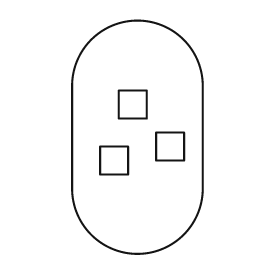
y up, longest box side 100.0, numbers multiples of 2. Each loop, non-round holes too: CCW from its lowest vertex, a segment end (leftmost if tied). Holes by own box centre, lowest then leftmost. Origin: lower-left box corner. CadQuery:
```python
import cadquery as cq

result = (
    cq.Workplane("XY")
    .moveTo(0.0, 28.0)
    .threePointArc((28.0, 0.0), (56.0, 28.0))
    .lineTo(56.0, 72.0)
    .threePointArc((28.0, 100.0), (0.0, 72.0))
    .close()
    .moveTo(12.0, 34.0)
    .lineTo(24.0, 34.0)
    .lineTo(24.0, 46.0)
    .lineTo(12.0, 46.0)
    .close()
    .moveTo(36.0, 40.0)
    .lineTo(48.0, 40.0)
    .lineTo(48.0, 52.0)
    .lineTo(36.0, 52.0)
    .close()
    .moveTo(20.0, 58.0)
    .lineTo(32.0, 58.0)
    .lineTo(32.0, 70.0)
    .lineTo(20.0, 70.0)
    .close()
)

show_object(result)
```